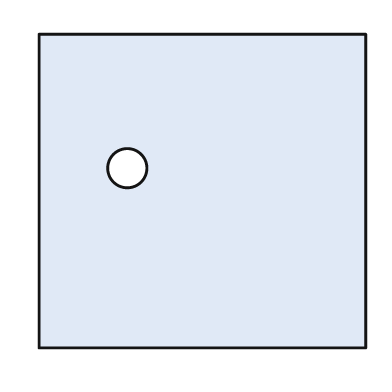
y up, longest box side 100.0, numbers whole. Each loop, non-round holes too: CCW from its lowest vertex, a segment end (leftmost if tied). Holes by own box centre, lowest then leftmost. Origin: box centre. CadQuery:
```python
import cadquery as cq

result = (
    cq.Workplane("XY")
    .moveTo(-50.0, -48.0)
    .lineTo(50.0, -48.0)
    .lineTo(50.0, 48.0)
    .lineTo(-50.0, 48.0)
    .close()
    .moveTo(-23.0, 7.0)
    .circle(6.0)
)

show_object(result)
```